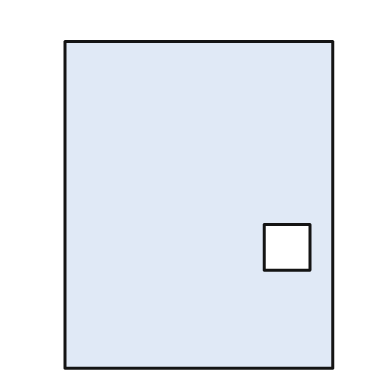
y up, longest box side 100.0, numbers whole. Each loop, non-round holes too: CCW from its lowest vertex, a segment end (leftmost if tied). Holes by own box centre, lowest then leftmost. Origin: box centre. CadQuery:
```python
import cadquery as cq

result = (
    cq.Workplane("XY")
    .moveTo(-41.0, -50.0)
    .lineTo(41.0, -50.0)
    .lineTo(41.0, 50.0)
    .lineTo(-41.0, 50.0)
    .close()
    .moveTo(20.0, -20.0)
    .lineTo(34.0, -20.0)
    .lineTo(34.0, -6.0)
    .lineTo(20.0, -6.0)
    .close()
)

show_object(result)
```